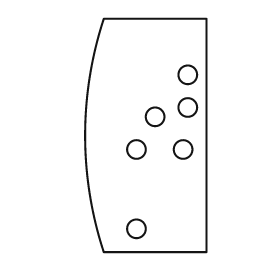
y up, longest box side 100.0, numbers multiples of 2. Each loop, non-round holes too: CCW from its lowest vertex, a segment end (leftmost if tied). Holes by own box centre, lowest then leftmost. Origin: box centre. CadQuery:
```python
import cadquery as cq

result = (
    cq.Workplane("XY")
    .moveTo(-18.0, -50.0)
    .lineTo(26.0, -50.0)
    .lineTo(26.0, 50.0)
    .lineTo(-18.0, 50.0)
    .threePointArc((-26.0, 0.0), (-18.0, -50.0))
    .close()
    .moveTo(-4.0, -40.0)
    .circle(4.0)
    .moveTo(-4.0, -6.0)
    .circle(4.0)
    .moveTo(16.0, -6.0)
    .circle(4.0)
    .moveTo(4.0, 8.0)
    .circle(4.0)
    .moveTo(18.0, 12.0)
    .circle(4.0)
    .moveTo(18.0, 26.0)
    .circle(4.0)
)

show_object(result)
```